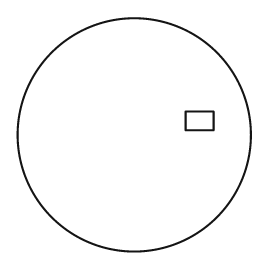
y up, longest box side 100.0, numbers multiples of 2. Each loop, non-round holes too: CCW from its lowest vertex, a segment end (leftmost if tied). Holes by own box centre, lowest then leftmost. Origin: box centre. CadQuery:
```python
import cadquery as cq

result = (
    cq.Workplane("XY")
    .moveTo(0.0, 0.0)
    .circle(50.0)
    .moveTo(22.0, 2.0)
    .lineTo(34.0, 2.0)
    .lineTo(34.0, 10.0)
    .lineTo(22.0, 10.0)
    .close()
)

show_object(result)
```